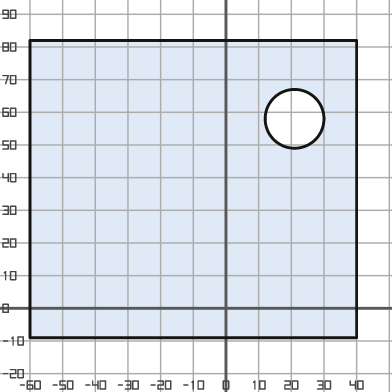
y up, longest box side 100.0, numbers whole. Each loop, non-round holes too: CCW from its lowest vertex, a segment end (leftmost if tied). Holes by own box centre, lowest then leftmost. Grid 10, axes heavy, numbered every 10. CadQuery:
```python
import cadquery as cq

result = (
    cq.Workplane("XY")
    .moveTo(-60.0, -9.0)
    .lineTo(40.0, -9.0)
    .lineTo(40.0, 82.0)
    .lineTo(-60.0, 82.0)
    .close()
    .moveTo(21.0, 58.0)
    .circle(9.0)
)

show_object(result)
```